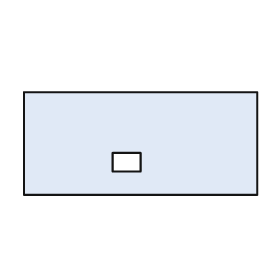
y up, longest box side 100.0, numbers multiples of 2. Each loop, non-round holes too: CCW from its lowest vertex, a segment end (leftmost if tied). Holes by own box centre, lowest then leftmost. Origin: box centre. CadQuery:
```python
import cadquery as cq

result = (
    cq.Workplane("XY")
    .moveTo(-50.0, -22.0)
    .lineTo(50.0, -22.0)
    .lineTo(50.0, 22.0)
    .lineTo(-50.0, 22.0)
    .close()
    .moveTo(-12.0, -12.0)
    .lineTo(0.0, -12.0)
    .lineTo(0.0, -4.0)
    .lineTo(-12.0, -4.0)
    .close()
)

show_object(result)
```